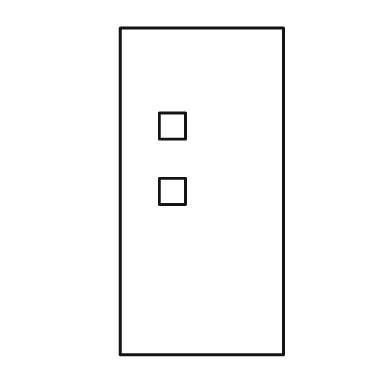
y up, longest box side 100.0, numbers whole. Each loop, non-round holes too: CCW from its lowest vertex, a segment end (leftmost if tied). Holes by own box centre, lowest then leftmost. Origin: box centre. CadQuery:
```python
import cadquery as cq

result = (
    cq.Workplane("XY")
    .moveTo(-25.0, -50.0)
    .lineTo(25.0, -50.0)
    .lineTo(25.0, 50.0)
    .lineTo(-25.0, 50.0)
    .close()
    .moveTo(-13.0, -4.0)
    .lineTo(-5.0, -4.0)
    .lineTo(-5.0, 4.0)
    .lineTo(-13.0, 4.0)
    .close()
    .moveTo(-13.0, 16.0)
    .lineTo(-5.0, 16.0)
    .lineTo(-5.0, 24.0)
    .lineTo(-13.0, 24.0)
    .close()
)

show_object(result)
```